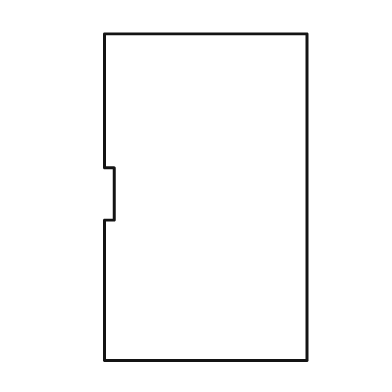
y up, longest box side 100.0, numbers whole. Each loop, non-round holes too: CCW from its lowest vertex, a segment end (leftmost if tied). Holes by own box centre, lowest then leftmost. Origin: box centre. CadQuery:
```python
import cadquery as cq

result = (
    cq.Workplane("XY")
    .moveTo(-31.0, -50.0)
    .lineTo(31.0, -50.0)
    .lineTo(31.0, 50.0)
    .lineTo(-31.0, 50.0)
    .lineTo(-31.0, 9.0)
    .lineTo(-28.0, 9.0)
    .lineTo(-28.0, -7.0)
    .lineTo(-31.0, -7.0)
    .close()
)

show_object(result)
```